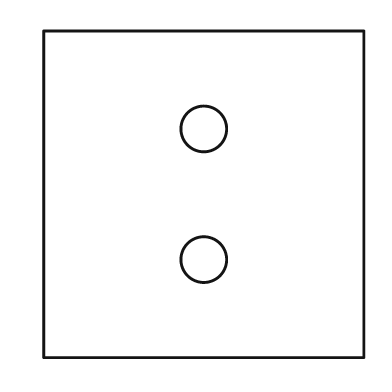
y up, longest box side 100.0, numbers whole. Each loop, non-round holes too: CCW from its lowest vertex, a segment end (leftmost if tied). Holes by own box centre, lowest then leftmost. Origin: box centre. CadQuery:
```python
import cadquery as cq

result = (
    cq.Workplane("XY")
    .moveTo(-49.0, -50.0)
    .lineTo(49.0, -50.0)
    .lineTo(49.0, 50.0)
    .lineTo(-49.0, 50.0)
    .close()
    .moveTo(0.0, -20.0)
    .circle(7.0)
    .moveTo(0.0, 20.0)
    .circle(7.0)
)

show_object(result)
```